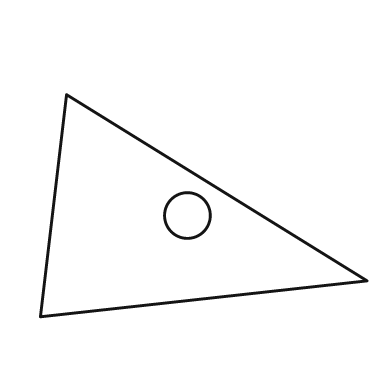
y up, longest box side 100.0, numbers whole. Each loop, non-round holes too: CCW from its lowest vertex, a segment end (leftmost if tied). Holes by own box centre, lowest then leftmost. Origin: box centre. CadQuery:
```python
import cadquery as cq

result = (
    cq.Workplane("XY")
    .moveTo(-50.0, -34.0)
    .lineTo(50.0, -23.0)
    .lineTo(-42.0, 34.0)
    .close()
    .moveTo(-5.0, -3.0)
    .circle(7.0)
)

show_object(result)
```